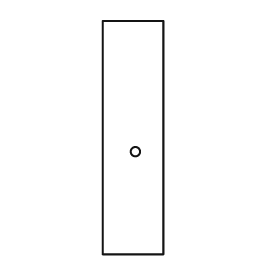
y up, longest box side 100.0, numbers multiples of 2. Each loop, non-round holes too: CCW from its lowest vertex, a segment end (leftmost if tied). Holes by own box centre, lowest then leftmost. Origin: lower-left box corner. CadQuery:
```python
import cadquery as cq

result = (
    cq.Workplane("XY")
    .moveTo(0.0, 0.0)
    .lineTo(26.0, 0.0)
    .lineTo(26.0, 100.0)
    .lineTo(0.0, 100.0)
    .close()
    .moveTo(14.0, 44.0)
    .circle(2.0)
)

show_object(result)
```